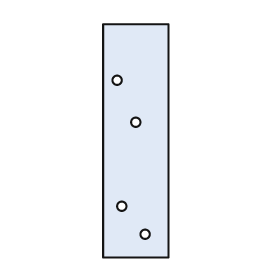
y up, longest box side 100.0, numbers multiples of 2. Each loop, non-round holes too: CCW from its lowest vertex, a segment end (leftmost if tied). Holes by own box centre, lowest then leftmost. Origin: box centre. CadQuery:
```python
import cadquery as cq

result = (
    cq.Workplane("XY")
    .moveTo(-14.0, -50.0)
    .lineTo(14.0, -50.0)
    .lineTo(14.0, 50.0)
    .lineTo(-14.0, 50.0)
    .close()
    .moveTo(4.0, -40.0)
    .circle(2.0)
    .moveTo(-6.0, -28.0)
    .circle(2.0)
    .moveTo(0.0, 8.0)
    .circle(2.0)
    .moveTo(-8.0, 26.0)
    .circle(2.0)
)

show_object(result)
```